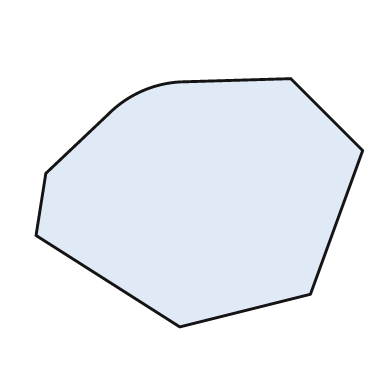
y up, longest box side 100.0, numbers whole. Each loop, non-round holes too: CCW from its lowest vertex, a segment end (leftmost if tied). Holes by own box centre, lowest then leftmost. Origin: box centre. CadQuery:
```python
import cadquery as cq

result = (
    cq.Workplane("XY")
    .moveTo(-6.0, -38.0)
    .lineTo(34.0, -28.0)
    .lineTo(50.0, 16.0)
    .lineTo(28.0, 38.0)
    .lineTo(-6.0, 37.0)
    .threePointArc((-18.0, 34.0), (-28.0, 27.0))
    .lineTo(-47.0, 9.0)
    .lineTo(-50.0, -10.0)
    .close()
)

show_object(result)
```